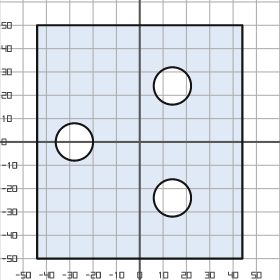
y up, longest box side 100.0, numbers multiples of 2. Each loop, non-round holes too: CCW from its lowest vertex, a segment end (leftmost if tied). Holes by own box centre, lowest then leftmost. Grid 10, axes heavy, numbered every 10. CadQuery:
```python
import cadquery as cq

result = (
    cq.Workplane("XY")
    .moveTo(-44.0, -50.0)
    .lineTo(44.0, -50.0)
    .lineTo(44.0, 50.0)
    .lineTo(-44.0, 50.0)
    .close()
    .moveTo(14.0, -24.0)
    .circle(8.0)
    .moveTo(-28.0, 0.0)
    .circle(8.0)
    .moveTo(14.0, 24.0)
    .circle(8.0)
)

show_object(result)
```